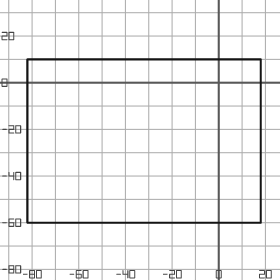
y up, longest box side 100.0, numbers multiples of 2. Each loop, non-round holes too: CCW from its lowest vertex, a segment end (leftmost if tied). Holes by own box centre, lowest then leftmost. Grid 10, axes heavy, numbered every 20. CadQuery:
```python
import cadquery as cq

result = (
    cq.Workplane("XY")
    .moveTo(-82.0, -60.0)
    .lineTo(18.0, -60.0)
    .lineTo(18.0, 10.0)
    .lineTo(-82.0, 10.0)
    .close()
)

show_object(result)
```